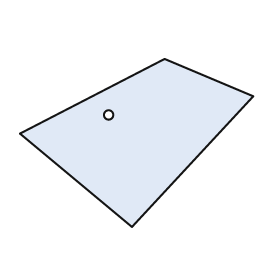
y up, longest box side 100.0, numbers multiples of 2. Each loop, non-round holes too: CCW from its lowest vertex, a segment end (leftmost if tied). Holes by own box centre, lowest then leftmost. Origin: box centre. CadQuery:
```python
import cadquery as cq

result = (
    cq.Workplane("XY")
    .moveTo(-2.0, -36.0)
    .lineTo(50.0, 20.0)
    .lineTo(12.0, 36.0)
    .lineTo(-50.0, 4.0)
    .close()
    .moveTo(-12.0, 12.0)
    .circle(2.0)
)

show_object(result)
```